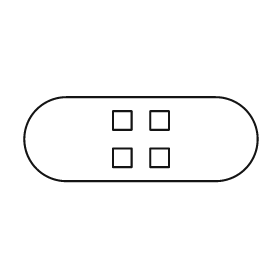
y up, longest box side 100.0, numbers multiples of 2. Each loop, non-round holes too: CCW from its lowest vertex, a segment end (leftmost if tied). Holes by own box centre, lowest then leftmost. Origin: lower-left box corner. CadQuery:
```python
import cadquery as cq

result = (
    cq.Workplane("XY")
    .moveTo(18.0, 0.0)
    .lineTo(82.0, 0.0)
    .threePointArc((100.0, 18.0), (82.0, 36.0))
    .lineTo(18.0, 36.0)
    .threePointArc((0.0, 18.0), (18.0, 0.0))
    .close()
    .moveTo(38.0, 6.0)
    .lineTo(46.0, 6.0)
    .lineTo(46.0, 14.0)
    .lineTo(38.0, 14.0)
    .close()
    .moveTo(54.0, 6.0)
    .lineTo(62.0, 6.0)
    .lineTo(62.0, 14.0)
    .lineTo(54.0, 14.0)
    .close()
    .moveTo(38.0, 22.0)
    .lineTo(46.0, 22.0)
    .lineTo(46.0, 30.0)
    .lineTo(38.0, 30.0)
    .close()
    .moveTo(54.0, 22.0)
    .lineTo(62.0, 22.0)
    .lineTo(62.0, 30.0)
    .lineTo(54.0, 30.0)
    .close()
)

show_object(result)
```